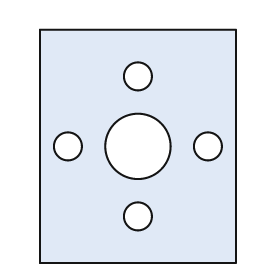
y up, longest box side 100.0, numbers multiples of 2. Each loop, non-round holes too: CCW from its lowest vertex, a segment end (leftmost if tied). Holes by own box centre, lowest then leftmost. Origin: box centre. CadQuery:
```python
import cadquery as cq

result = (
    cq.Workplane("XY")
    .moveTo(-42.0, -50.0)
    .lineTo(42.0, -50.0)
    .lineTo(42.0, 50.0)
    .lineTo(-42.0, 50.0)
    .close()
    .moveTo(0.0, -30.0)
    .circle(6.0)
    .moveTo(-30.0, 0.0)
    .circle(6.0)
    .moveTo(0.0, 0.0)
    .circle(14.0)
    .moveTo(30.0, 0.0)
    .circle(6.0)
    .moveTo(0.0, 30.0)
    .circle(6.0)
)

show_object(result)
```